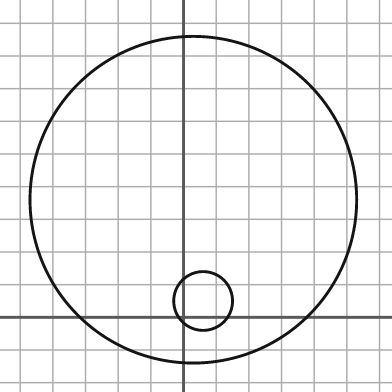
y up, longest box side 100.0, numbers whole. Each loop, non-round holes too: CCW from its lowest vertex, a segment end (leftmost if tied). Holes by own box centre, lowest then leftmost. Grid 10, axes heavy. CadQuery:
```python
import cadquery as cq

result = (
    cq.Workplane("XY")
    .moveTo(3.0, 36.0)
    .circle(50.0)
    .moveTo(6.0, 5.0)
    .circle(9.0)
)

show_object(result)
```